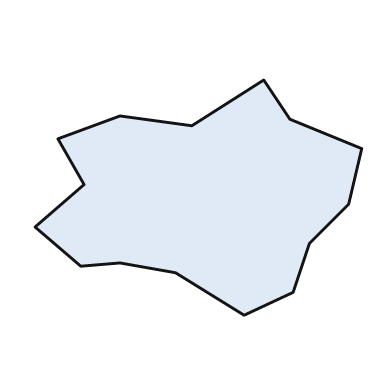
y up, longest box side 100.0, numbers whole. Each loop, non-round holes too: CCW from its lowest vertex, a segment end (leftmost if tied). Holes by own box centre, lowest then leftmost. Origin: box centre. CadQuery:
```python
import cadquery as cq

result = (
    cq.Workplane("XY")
    .moveTo(14.0, -36.0)
    .lineTo(29.0, -29.0)
    .lineTo(34.0, -14.0)
    .lineTo(46.0, -2.0)
    .lineTo(50.0, 15.0)
    .lineTo(28.0, 24.0)
    .lineTo(20.0, 36.0)
    .lineTo(-2.0, 22.0)
    .lineTo(-24.0, 25.0)
    .lineTo(-43.0, 18.0)
    .lineTo(-35.0, 4.0)
    .lineTo(-50.0, -9.0)
    .lineTo(-36.0, -21.0)
    .lineTo(-24.0, -20.0)
    .lineTo(-7.0, -23.0)
    .close()
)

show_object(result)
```